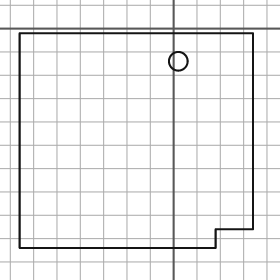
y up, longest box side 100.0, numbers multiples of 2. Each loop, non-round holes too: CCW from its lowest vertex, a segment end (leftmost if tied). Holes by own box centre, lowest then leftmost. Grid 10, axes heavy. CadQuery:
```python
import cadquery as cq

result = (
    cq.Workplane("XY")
    .moveTo(-66.0, -94.0)
    .lineTo(18.0, -94.0)
    .lineTo(18.0, -86.0)
    .lineTo(34.0, -86.0)
    .lineTo(34.0, -2.0)
    .lineTo(-66.0, -2.0)
    .close()
    .moveTo(2.0, -14.0)
    .circle(4.0)
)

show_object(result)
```